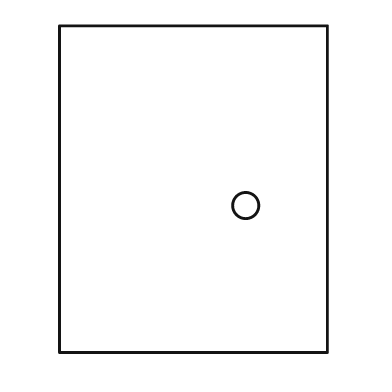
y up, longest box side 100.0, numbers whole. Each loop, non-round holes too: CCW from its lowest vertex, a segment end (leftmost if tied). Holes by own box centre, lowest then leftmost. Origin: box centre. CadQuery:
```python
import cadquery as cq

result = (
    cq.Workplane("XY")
    .moveTo(-41.0, -50.0)
    .lineTo(41.0, -50.0)
    .lineTo(41.0, 50.0)
    .lineTo(-41.0, 50.0)
    .close()
    .moveTo(16.0, -5.0)
    .circle(4.0)
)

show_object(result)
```